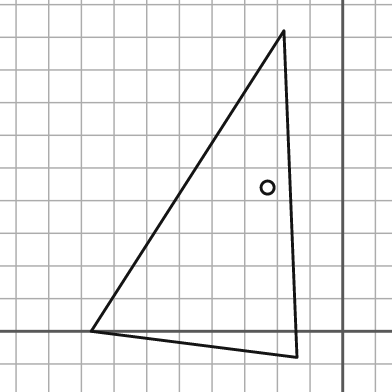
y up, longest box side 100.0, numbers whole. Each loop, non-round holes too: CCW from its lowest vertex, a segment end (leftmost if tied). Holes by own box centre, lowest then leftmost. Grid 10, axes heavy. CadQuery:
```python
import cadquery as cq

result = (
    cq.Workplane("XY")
    .moveTo(-14.0, -8.0)
    .lineTo(-18.0, 92.0)
    .lineTo(-77.0, 0.0)
    .close()
    .moveTo(-23.0, 44.0)
    .circle(2.0)
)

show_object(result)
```